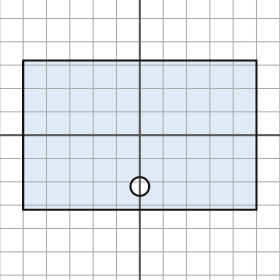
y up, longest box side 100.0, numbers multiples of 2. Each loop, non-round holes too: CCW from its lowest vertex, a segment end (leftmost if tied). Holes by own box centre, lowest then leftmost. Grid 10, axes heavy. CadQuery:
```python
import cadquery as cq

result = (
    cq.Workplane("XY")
    .moveTo(-50.0, -32.0)
    .lineTo(50.0, -32.0)
    .lineTo(50.0, 32.0)
    .lineTo(-50.0, 32.0)
    .close()
    .moveTo(0.0, -22.0)
    .circle(4.0)
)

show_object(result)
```